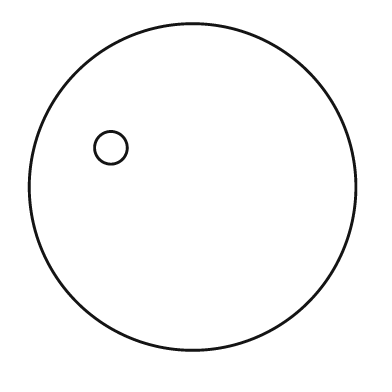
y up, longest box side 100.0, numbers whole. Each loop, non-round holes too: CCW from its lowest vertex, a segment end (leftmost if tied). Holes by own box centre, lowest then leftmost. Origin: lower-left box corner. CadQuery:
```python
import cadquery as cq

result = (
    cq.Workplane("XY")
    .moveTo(50.0, 50.0)
    .circle(50.0)
    .moveTo(25.0, 62.0)
    .circle(5.0)
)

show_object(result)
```